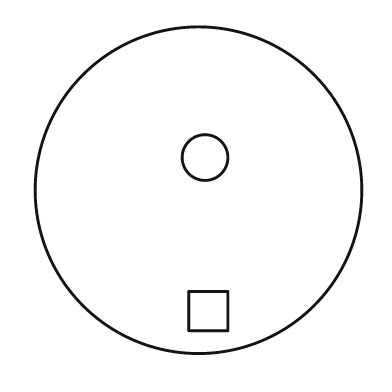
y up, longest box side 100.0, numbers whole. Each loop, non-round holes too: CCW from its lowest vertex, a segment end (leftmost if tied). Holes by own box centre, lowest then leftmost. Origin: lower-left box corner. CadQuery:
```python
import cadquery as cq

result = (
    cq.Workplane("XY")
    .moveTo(50.0, 50.0)
    .circle(50.0)
    .moveTo(47.0, 7.0)
    .lineTo(59.0, 7.0)
    .lineTo(59.0, 19.0)
    .lineTo(47.0, 19.0)
    .close()
    .moveTo(52.0, 60.0)
    .circle(7.0)
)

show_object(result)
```